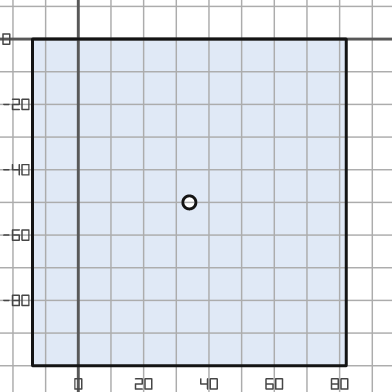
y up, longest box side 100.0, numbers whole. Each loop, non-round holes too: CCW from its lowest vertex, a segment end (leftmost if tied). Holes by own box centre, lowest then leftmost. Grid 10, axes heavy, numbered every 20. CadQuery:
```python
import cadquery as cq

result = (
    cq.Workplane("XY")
    .moveTo(-14.0, -100.0)
    .lineTo(82.0, -100.0)
    .lineTo(82.0, 0.0)
    .lineTo(-14.0, 0.0)
    .close()
    .moveTo(34.0, -50.0)
    .circle(2.0)
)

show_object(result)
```